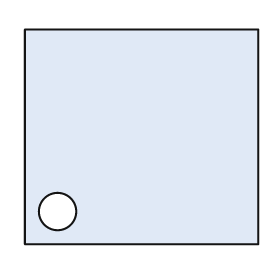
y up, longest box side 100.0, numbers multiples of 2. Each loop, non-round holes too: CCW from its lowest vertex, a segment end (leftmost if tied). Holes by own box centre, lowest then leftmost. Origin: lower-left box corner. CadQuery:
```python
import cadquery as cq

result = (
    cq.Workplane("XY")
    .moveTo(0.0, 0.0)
    .lineTo(100.0, 0.0)
    .lineTo(100.0, 92.0)
    .lineTo(0.0, 92.0)
    .close()
    .moveTo(14.0, 14.0)
    .circle(8.0)
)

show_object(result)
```